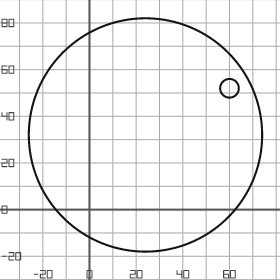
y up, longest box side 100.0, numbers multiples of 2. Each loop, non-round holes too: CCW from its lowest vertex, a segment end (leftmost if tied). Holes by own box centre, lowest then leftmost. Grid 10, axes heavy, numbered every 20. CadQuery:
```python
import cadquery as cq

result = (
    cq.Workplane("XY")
    .moveTo(24.0, 32.0)
    .circle(50.0)
    .moveTo(60.0, 52.0)
    .circle(4.0)
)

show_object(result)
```